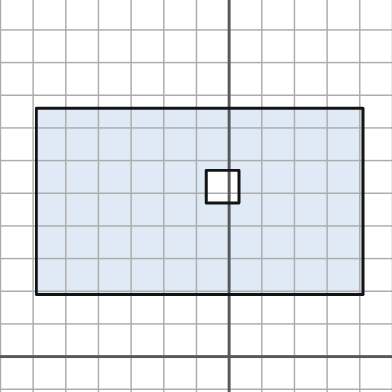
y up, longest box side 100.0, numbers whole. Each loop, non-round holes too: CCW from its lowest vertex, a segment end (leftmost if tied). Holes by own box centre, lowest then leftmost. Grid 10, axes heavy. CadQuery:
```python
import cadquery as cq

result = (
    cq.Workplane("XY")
    .moveTo(-59.0, 19.0)
    .lineTo(41.0, 19.0)
    .lineTo(41.0, 76.0)
    .lineTo(-59.0, 76.0)
    .close()
    .moveTo(-7.0, 47.0)
    .lineTo(3.0, 47.0)
    .lineTo(3.0, 57.0)
    .lineTo(-7.0, 57.0)
    .close()
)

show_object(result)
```